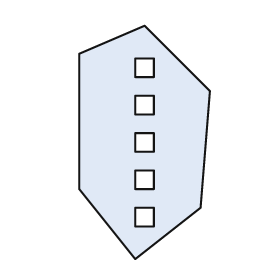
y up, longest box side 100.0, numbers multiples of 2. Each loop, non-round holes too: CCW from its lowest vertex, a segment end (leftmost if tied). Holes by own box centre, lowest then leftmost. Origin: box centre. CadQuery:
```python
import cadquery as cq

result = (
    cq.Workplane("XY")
    .moveTo(-4.0, -50.0)
    .lineTo(24.0, -28.0)
    .lineTo(28.0, 22.0)
    .lineTo(0.0, 50.0)
    .lineTo(-28.0, 38.0)
    .lineTo(-28.0, -20.0)
    .close()
    .moveTo(-4.0, -36.0)
    .lineTo(4.0, -36.0)
    .lineTo(4.0, -28.0)
    .lineTo(-4.0, -28.0)
    .close()
    .moveTo(-4.0, -20.0)
    .lineTo(4.0, -20.0)
    .lineTo(4.0, -12.0)
    .lineTo(-4.0, -12.0)
    .close()
    .moveTo(-4.0, -4.0)
    .lineTo(4.0, -4.0)
    .lineTo(4.0, 4.0)
    .lineTo(-4.0, 4.0)
    .close()
    .moveTo(-4.0, 12.0)
    .lineTo(4.0, 12.0)
    .lineTo(4.0, 20.0)
    .lineTo(-4.0, 20.0)
    .close()
    .moveTo(-4.0, 28.0)
    .lineTo(4.0, 28.0)
    .lineTo(4.0, 36.0)
    .lineTo(-4.0, 36.0)
    .close()
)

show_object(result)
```